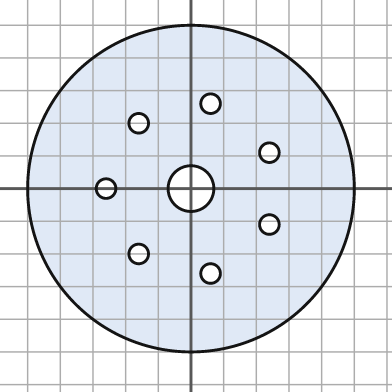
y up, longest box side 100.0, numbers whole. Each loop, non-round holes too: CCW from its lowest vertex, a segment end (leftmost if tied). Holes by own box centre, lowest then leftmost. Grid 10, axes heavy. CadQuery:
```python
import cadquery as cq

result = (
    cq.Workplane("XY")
    .moveTo(0.0, 0.0)
    .circle(50.0)
    .moveTo(6.0, -26.0)
    .circle(3.0)
    .moveTo(-16.0, -20.0)
    .circle(3.0)
    .moveTo(24.0, -11.0)
    .circle(3.0)
    .moveTo(-26.0, 0.0)
    .circle(3.0)
    .moveTo(0.0, 0.0)
    .circle(7.0)
    .moveTo(24.0, 11.0)
    .circle(3.0)
    .moveTo(-16.0, 20.0)
    .circle(3.0)
    .moveTo(6.0, 26.0)
    .circle(3.0)
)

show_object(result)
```